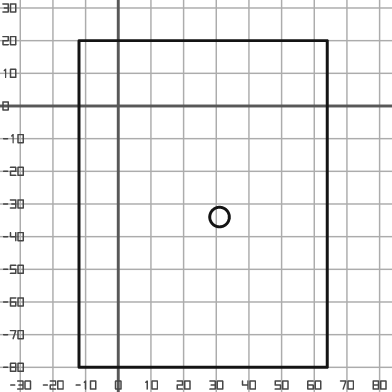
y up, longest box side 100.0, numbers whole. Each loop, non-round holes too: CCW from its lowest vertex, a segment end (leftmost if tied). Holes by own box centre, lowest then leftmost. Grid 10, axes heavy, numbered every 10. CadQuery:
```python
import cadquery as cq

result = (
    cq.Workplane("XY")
    .moveTo(-12.0, -80.0)
    .lineTo(64.0, -80.0)
    .lineTo(64.0, 20.0)
    .lineTo(-12.0, 20.0)
    .close()
    .moveTo(31.0, -34.0)
    .circle(3.0)
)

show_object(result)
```